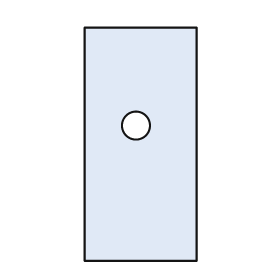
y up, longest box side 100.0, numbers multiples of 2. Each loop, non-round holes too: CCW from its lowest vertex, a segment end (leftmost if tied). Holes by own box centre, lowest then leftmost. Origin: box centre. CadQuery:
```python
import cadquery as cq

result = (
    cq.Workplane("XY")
    .moveTo(-24.0, -50.0)
    .lineTo(24.0, -50.0)
    .lineTo(24.0, 50.0)
    .lineTo(-24.0, 50.0)
    .close()
    .moveTo(-2.0, 8.0)
    .circle(6.0)
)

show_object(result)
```